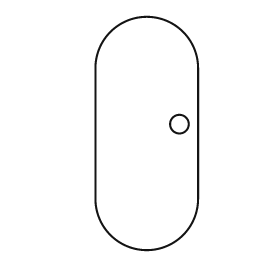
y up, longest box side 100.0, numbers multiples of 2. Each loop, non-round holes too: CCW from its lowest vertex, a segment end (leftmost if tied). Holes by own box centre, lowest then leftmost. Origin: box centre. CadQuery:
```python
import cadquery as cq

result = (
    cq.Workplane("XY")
    .moveTo(-22.0, -28.0)
    .threePointArc((0.0, -50.0), (22.0, -28.0))
    .lineTo(22.0, 28.0)
    .threePointArc((0.0, 50.0), (-22.0, 28.0))
    .close()
    .moveTo(14.0, 4.0)
    .circle(4.0)
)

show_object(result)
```